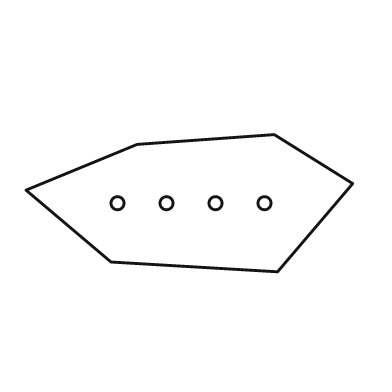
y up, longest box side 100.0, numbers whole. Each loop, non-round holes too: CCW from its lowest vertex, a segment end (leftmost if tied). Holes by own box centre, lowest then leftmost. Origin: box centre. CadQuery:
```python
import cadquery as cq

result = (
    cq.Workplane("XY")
    .moveTo(27.0, -21.0)
    .lineTo(50.0, 6.0)
    .lineTo(26.0, 21.0)
    .lineTo(-16.0, 18.0)
    .lineTo(-50.0, 4.0)
    .lineTo(-24.0, -18.0)
    .close()
    .moveTo(-22.0, 0.0)
    .circle(2.0)
    .moveTo(-7.0, 0.0)
    .circle(2.0)
    .moveTo(8.0, 0.0)
    .circle(2.0)
    .moveTo(23.0, 0.0)
    .circle(2.0)
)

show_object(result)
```